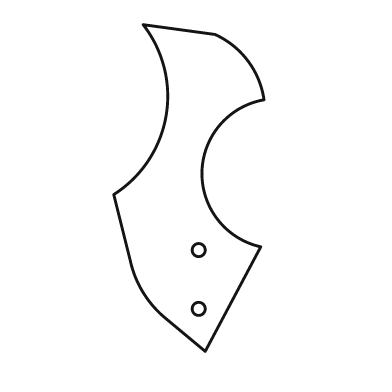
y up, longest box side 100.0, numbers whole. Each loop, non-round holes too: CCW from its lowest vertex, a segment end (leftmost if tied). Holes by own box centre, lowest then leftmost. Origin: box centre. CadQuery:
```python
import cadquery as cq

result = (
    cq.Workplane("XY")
    .moveTo(5.0, -50.0)
    .lineTo(22.0, -18.0)
    .threePointArc((4.0, 5.0), (23.0, 27.0))
    .threePointArc((18.0, 39.0), (8.0, 47.0))
    .lineTo(-14.0, 50.0)
    .threePointArc((-7.0, 22.0), (-23.0, -2.0))
    .lineTo(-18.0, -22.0)
    .threePointArc((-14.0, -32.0), (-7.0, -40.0))
    .close()
    .moveTo(3.0, -37.0)
    .circle(2.0)
    .moveTo(3.0, -19.0)
    .circle(2.0)
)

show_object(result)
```